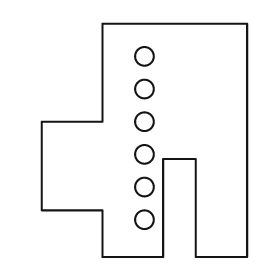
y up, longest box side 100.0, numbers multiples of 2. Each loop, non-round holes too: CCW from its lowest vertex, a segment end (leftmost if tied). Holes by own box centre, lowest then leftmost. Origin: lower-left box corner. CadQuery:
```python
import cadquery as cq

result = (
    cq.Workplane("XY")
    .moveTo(26.0, 0.0)
    .lineTo(52.0, 0.0)
    .lineTo(52.0, 42.0)
    .lineTo(66.0, 42.0)
    .lineTo(66.0, 0.0)
    .lineTo(88.0, 0.0)
    .lineTo(88.0, 100.0)
    .lineTo(26.0, 100.0)
    .lineTo(26.0, 58.0)
    .lineTo(0.0, 58.0)
    .lineTo(0.0, 20.0)
    .lineTo(26.0, 20.0)
    .close()
    .moveTo(44.0, 16.0)
    .circle(4.0)
    .moveTo(44.0, 30.0)
    .circle(4.0)
    .moveTo(44.0, 44.0)
    .circle(4.0)
    .moveTo(44.0, 58.0)
    .circle(4.0)
    .moveTo(44.0, 72.0)
    .circle(4.0)
    .moveTo(44.0, 86.0)
    .circle(4.0)
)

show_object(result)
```